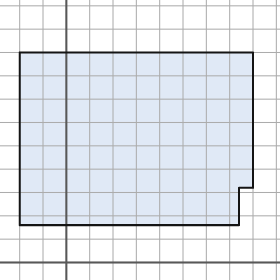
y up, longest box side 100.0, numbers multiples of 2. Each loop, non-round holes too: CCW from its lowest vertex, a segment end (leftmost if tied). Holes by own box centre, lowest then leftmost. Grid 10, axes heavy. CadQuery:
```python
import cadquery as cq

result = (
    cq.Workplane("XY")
    .moveTo(-20.0, 16.0)
    .lineTo(74.0, 16.0)
    .lineTo(74.0, 32.0)
    .lineTo(80.0, 32.0)
    .lineTo(80.0, 90.0)
    .lineTo(-20.0, 90.0)
    .close()
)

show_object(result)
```